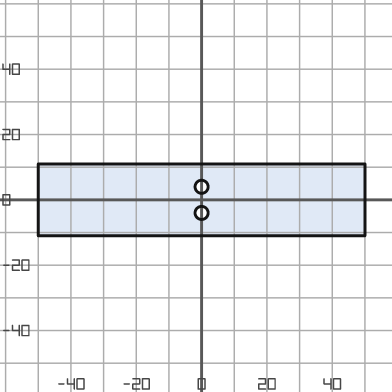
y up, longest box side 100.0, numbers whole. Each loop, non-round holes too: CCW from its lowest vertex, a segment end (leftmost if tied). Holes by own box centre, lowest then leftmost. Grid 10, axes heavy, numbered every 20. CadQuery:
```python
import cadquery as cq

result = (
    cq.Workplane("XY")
    .moveTo(-50.0, -11.0)
    .lineTo(50.0, -11.0)
    .lineTo(50.0, 11.0)
    .lineTo(-50.0, 11.0)
    .close()
    .moveTo(0.0, -4.0)
    .circle(2.0)
    .moveTo(0.0, 4.0)
    .circle(2.0)
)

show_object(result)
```